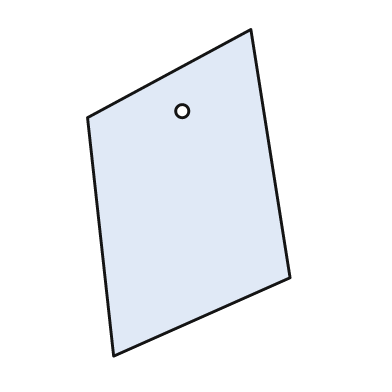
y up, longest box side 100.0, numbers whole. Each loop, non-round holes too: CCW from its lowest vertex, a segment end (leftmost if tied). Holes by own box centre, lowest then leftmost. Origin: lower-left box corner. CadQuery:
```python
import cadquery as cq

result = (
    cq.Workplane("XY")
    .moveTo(8.0, 0.0)
    .lineTo(62.0, 24.0)
    .lineTo(50.0, 100.0)
    .lineTo(0.0, 73.0)
    .close()
    .moveTo(29.0, 75.0)
    .circle(2.0)
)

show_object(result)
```